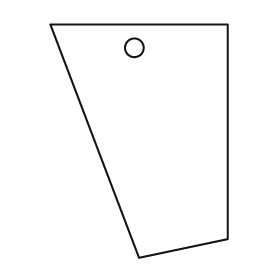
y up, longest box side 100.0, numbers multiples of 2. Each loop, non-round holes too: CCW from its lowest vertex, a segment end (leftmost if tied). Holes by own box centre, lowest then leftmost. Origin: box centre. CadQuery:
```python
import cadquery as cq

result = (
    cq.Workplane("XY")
    .moveTo(0.0, -50.0)
    .lineTo(38.0, -42.0)
    .lineTo(38.0, 50.0)
    .lineTo(-38.0, 50.0)
    .close()
    .moveTo(-2.0, 40.0)
    .circle(4.0)
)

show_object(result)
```